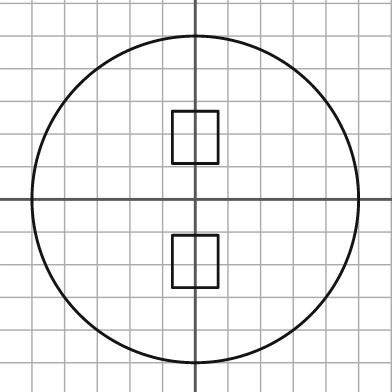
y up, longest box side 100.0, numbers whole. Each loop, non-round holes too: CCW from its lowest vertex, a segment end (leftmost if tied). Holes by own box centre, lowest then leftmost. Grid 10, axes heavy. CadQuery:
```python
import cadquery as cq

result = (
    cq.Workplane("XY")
    .moveTo(0.0, 0.0)
    .circle(50.0)
    .moveTo(-7.0, -27.0)
    .lineTo(7.0, -27.0)
    .lineTo(7.0, -11.0)
    .lineTo(-7.0, -11.0)
    .close()
    .moveTo(-7.0, 11.0)
    .lineTo(7.0, 11.0)
    .lineTo(7.0, 27.0)
    .lineTo(-7.0, 27.0)
    .close()
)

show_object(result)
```